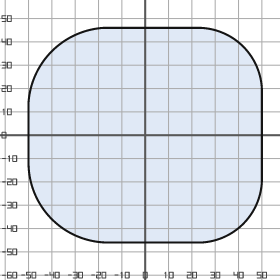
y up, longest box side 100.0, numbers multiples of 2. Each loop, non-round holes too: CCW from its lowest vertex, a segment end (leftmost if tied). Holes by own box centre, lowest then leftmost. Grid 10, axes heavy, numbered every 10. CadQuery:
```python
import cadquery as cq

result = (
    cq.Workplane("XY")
    .moveTo(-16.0, -46.0)
    .lineTo(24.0, -46.0)
    .threePointArc((42.0, -38.0), (50.0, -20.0))
    .lineTo(50.0, 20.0)
    .threePointArc((42.0, 38.0), (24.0, 46.0))
    .lineTo(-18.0, 46.0)
    .threePointArc((-40.0, 36.0), (-50.0, 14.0))
    .lineTo(-50.0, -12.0)
    .threePointArc((-40.0, -36.0), (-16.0, -46.0))
    .close()
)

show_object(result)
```